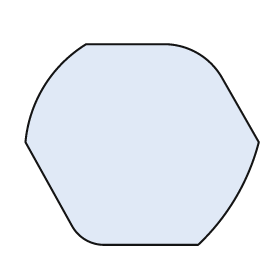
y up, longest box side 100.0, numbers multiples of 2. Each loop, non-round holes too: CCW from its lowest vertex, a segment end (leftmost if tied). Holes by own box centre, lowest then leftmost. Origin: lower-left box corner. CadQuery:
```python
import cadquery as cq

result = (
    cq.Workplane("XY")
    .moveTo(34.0, 0.0)
    .lineTo(74.0, 0.0)
    .threePointArc((90.0, 20.0), (100.0, 44.0))
    .lineTo(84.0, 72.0)
    .threePointArc((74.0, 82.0), (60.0, 86.0))
    .lineTo(26.0, 86.0)
    .threePointArc((8.0, 68.0), (0.0, 44.0))
    .lineTo(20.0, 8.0)
    .threePointArc((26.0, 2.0), (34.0, 0.0))
    .close()
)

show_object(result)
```